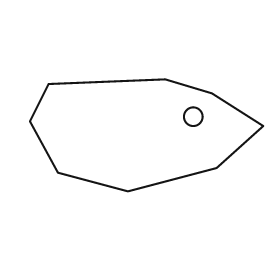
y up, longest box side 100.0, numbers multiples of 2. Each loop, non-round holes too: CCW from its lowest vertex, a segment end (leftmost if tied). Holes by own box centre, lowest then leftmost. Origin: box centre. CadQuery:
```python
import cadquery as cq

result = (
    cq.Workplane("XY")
    .moveTo(-8.0, -24.0)
    .lineTo(30.0, -14.0)
    .lineTo(50.0, 4.0)
    .lineTo(28.0, 18.0)
    .lineTo(8.0, 24.0)
    .lineTo(-42.0, 22.0)
    .lineTo(-50.0, 6.0)
    .lineTo(-38.0, -16.0)
    .close()
    .moveTo(20.0, 8.0)
    .circle(4.0)
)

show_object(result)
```